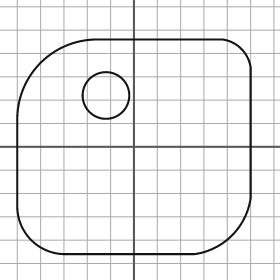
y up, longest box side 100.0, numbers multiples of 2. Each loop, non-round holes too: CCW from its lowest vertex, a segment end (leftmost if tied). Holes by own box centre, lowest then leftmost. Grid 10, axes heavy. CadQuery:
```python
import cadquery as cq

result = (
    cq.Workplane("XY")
    .moveTo(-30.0, -46.0)
    .lineTo(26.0, -46.0)
    .threePointArc((42.0, -38.0), (50.0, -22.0))
    .lineTo(50.0, 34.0)
    .threePointArc((46.0, 42.0), (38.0, 46.0))
    .lineTo(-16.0, 46.0)
    .threePointArc((-40.0, 36.0), (-50.0, 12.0))
    .lineTo(-50.0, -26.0)
    .threePointArc((-44.0, -40.0), (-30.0, -46.0))
    .close()
    .moveTo(-12.0, 22.0)
    .circle(10.0)
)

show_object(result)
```